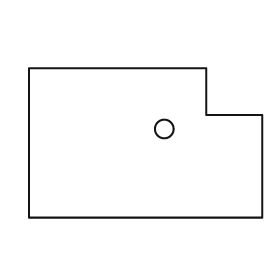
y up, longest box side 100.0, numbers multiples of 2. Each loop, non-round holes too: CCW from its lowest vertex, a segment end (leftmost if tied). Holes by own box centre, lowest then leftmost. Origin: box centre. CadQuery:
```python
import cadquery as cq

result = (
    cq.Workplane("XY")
    .moveTo(-50.0, -32.0)
    .lineTo(50.0, -32.0)
    .lineTo(50.0, 12.0)
    .lineTo(26.0, 12.0)
    .lineTo(26.0, 32.0)
    .lineTo(-50.0, 32.0)
    .close()
    .moveTo(8.0, 6.0)
    .circle(4.0)
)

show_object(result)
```